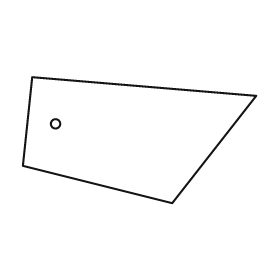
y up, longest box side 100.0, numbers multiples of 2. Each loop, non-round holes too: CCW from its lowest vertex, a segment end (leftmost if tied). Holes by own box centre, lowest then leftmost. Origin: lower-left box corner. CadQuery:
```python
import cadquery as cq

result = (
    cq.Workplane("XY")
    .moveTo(64.0, 0.0)
    .lineTo(100.0, 46.0)
    .lineTo(4.0, 54.0)
    .lineTo(0.0, 16.0)
    .close()
    .moveTo(14.0, 34.0)
    .circle(2.0)
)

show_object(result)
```